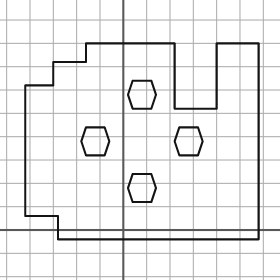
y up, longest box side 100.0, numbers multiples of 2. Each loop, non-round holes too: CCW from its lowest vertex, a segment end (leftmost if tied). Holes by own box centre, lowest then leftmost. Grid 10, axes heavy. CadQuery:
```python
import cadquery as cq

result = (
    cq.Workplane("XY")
    .moveTo(-28.0, -4.0)
    .lineTo(58.0, -4.0)
    .lineTo(58.0, 80.0)
    .lineTo(40.0, 80.0)
    .lineTo(40.0, 52.0)
    .lineTo(22.0, 52.0)
    .lineTo(22.0, 80.0)
    .lineTo(-16.0, 80.0)
    .lineTo(-16.0, 72.0)
    .lineTo(-30.0, 72.0)
    .lineTo(-30.0, 62.0)
    .lineTo(-42.0, 62.0)
    .lineTo(-42.0, 6.0)
    .lineTo(-28.0, 6.0)
    .close()
    .moveTo(4.0, 12.0)
    .lineTo(12.0, 12.0)
    .lineTo(14.0, 18.0)
    .lineTo(12.0, 24.0)
    .lineTo(4.0, 24.0)
    .lineTo(2.0, 18.0)
    .close()
    .moveTo(-16.0, 32.0)
    .lineTo(-8.0, 32.0)
    .lineTo(-6.0, 38.0)
    .lineTo(-8.0, 44.0)
    .lineTo(-16.0, 44.0)
    .lineTo(-18.0, 38.0)
    .close()
    .moveTo(24.0, 32.0)
    .lineTo(32.0, 32.0)
    .lineTo(34.0, 38.0)
    .lineTo(32.0, 44.0)
    .lineTo(24.0, 44.0)
    .lineTo(22.0, 38.0)
    .close()
    .moveTo(4.0, 52.0)
    .lineTo(12.0, 52.0)
    .lineTo(14.0, 58.0)
    .lineTo(12.0, 64.0)
    .lineTo(4.0, 64.0)
    .lineTo(2.0, 58.0)
    .close()
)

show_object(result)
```